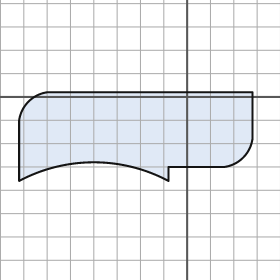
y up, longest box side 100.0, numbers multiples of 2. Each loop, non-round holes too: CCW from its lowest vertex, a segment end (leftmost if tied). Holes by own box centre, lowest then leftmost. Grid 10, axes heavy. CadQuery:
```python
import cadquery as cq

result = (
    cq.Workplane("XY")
    .moveTo(-72.0, -36.0)
    .threePointArc((-40.0, -28.0), (-8.0, -36.0))
    .lineTo(-8.0, -30.0)
    .lineTo(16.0, -30.0)
    .threePointArc((24.0, -26.0), (28.0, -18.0))
    .lineTo(28.0, 2.0)
    .lineTo(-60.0, 2.0)
    .threePointArc((-68.0, -2.0), (-72.0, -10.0))
    .close()
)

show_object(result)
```